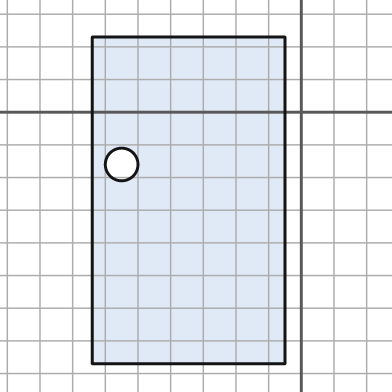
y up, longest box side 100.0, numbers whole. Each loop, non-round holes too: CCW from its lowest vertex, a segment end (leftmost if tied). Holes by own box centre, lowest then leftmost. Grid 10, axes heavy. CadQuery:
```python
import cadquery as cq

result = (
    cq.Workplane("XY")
    .moveTo(-64.0, -77.0)
    .lineTo(-5.0, -77.0)
    .lineTo(-5.0, 23.0)
    .lineTo(-64.0, 23.0)
    .close()
    .moveTo(-55.0, -16.0)
    .circle(5.0)
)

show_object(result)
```